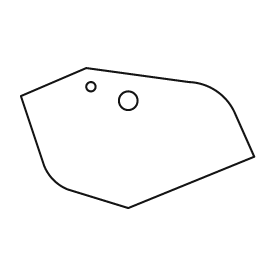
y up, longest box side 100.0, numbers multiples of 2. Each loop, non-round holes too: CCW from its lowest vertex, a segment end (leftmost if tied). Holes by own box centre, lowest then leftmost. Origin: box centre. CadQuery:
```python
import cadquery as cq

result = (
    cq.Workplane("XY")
    .moveTo(-4.0, -30.0)
    .lineTo(50.0, -8.0)
    .lineTo(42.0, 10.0)
    .threePointArc((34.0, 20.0), (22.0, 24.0))
    .lineTo(-22.0, 30.0)
    .lineTo(-50.0, 18.0)
    .lineTo(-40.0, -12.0)
    .threePointArc((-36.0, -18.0), (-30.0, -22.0))
    .close()
    .moveTo(-4.0, 16.0)
    .circle(4.0)
    .moveTo(-20.0, 22.0)
    .circle(2.0)
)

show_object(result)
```